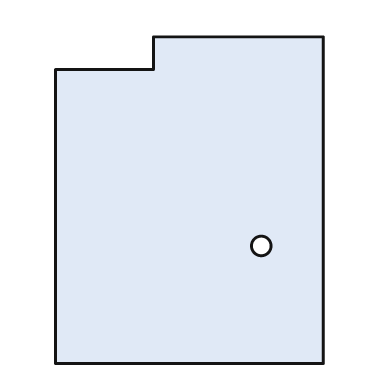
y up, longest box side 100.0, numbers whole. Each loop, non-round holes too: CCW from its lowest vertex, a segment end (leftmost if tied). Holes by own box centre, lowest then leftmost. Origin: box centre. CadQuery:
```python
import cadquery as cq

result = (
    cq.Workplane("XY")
    .moveTo(-41.0, -50.0)
    .lineTo(41.0, -50.0)
    .lineTo(41.0, 50.0)
    .lineTo(-11.0, 50.0)
    .lineTo(-11.0, 40.0)
    .lineTo(-41.0, 40.0)
    .close()
    .moveTo(22.0, -14.0)
    .circle(3.0)
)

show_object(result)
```